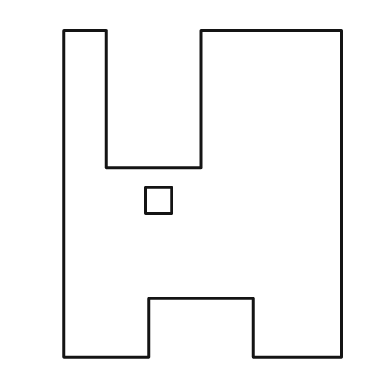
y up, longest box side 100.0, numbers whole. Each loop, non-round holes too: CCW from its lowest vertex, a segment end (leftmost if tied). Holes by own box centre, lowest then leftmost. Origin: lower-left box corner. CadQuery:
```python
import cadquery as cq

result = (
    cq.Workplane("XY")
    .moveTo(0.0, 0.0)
    .lineTo(26.0, 0.0)
    .lineTo(26.0, 18.0)
    .lineTo(58.0, 18.0)
    .lineTo(58.0, 0.0)
    .lineTo(85.0, 0.0)
    .lineTo(85.0, 100.0)
    .lineTo(42.0, 100.0)
    .lineTo(42.0, 58.0)
    .lineTo(13.0, 58.0)
    .lineTo(13.0, 100.0)
    .lineTo(0.0, 100.0)
    .close()
    .moveTo(25.0, 44.0)
    .lineTo(33.0, 44.0)
    .lineTo(33.0, 52.0)
    .lineTo(25.0, 52.0)
    .close()
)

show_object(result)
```